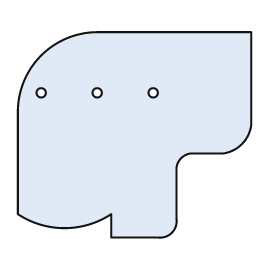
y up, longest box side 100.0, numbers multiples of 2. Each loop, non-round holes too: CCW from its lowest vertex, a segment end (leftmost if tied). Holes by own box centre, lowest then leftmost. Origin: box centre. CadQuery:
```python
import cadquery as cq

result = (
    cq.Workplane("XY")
    .moveTo(-10.0, -44.0)
    .lineTo(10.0, -44.0)
    .threePointArc((16.0, -42.0), (18.0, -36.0))
    .lineTo(18.0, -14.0)
    .threePointArc((20.0, -10.0), (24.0, -8.0))
    .lineTo(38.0, -8.0)
    .threePointArc((46.0, -4.0), (50.0, 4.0))
    .lineTo(50.0, 44.0)
    .lineTo(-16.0, 44.0)
    .threePointArc((-40.0, 34.0), (-50.0, 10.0))
    .lineTo(-50.0, -34.0)
    .threePointArc((-30.0, -40.0), (-10.0, -34.0))
    .close()
    .moveTo(-40.0, 18.0)
    .circle(2.0)
    .moveTo(-16.0, 18.0)
    .circle(2.0)
    .moveTo(8.0, 18.0)
    .circle(2.0)
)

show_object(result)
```